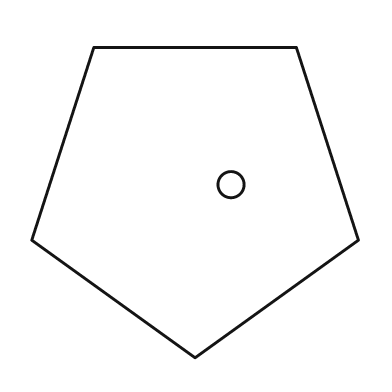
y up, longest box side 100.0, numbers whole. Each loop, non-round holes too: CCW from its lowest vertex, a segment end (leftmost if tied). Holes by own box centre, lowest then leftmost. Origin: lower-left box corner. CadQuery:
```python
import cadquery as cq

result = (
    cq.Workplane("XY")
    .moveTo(50.0, 0.0)
    .lineTo(100.0, 36.0)
    .lineTo(81.0, 95.0)
    .lineTo(19.0, 95.0)
    .lineTo(0.0, 36.0)
    .close()
    .moveTo(61.0, 53.0)
    .circle(4.0)
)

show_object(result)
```